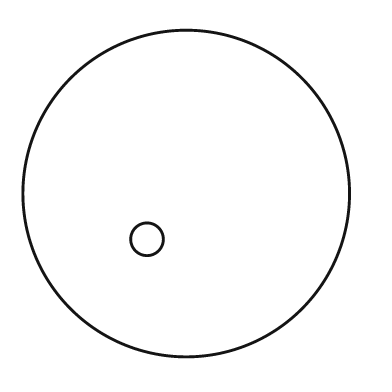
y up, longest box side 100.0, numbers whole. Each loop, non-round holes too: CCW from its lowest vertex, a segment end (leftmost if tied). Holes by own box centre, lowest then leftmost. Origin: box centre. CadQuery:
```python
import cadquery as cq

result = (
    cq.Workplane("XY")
    .moveTo(0.0, 0.0)
    .circle(50.0)
    .moveTo(-12.0, -14.0)
    .circle(5.0)
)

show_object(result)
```